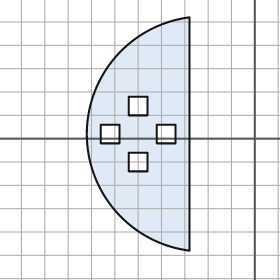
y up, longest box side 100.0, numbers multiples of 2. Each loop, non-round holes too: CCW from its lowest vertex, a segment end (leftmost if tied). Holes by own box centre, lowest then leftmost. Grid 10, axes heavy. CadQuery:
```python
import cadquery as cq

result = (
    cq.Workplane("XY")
    .moveTo(-28.0, -48.0)
    .lineTo(-28.0, 52.0)
    .threePointArc((-72.0, 2.0), (-28.0, -48.0))
    .close()
    .moveTo(-54.0, -14.0)
    .lineTo(-46.0, -14.0)
    .lineTo(-46.0, -6.0)
    .lineTo(-54.0, -6.0)
    .close()
    .moveTo(-66.0, -2.0)
    .lineTo(-58.0, -2.0)
    .lineTo(-58.0, 6.0)
    .lineTo(-66.0, 6.0)
    .close()
    .moveTo(-42.0, -2.0)
    .lineTo(-34.0, -2.0)
    .lineTo(-34.0, 6.0)
    .lineTo(-42.0, 6.0)
    .close()
    .moveTo(-54.0, 10.0)
    .lineTo(-46.0, 10.0)
    .lineTo(-46.0, 18.0)
    .lineTo(-54.0, 18.0)
    .close()
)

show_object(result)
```